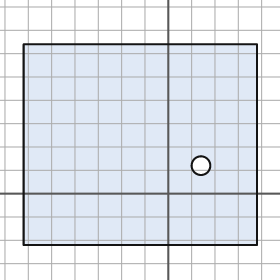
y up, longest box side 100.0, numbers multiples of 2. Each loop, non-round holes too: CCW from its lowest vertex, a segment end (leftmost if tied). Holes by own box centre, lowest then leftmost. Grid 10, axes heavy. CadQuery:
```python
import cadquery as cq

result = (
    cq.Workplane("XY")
    .moveTo(-62.0, -22.0)
    .lineTo(38.0, -22.0)
    .lineTo(38.0, 64.0)
    .lineTo(-62.0, 64.0)
    .close()
    .moveTo(14.0, 12.0)
    .circle(4.0)
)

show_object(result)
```